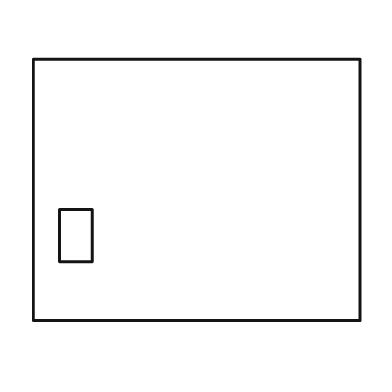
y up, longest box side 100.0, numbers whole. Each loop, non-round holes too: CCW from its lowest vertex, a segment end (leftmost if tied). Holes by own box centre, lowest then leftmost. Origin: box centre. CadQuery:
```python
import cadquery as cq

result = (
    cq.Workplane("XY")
    .moveTo(-50.0, -40.0)
    .lineTo(50.0, -40.0)
    .lineTo(50.0, 40.0)
    .lineTo(-50.0, 40.0)
    .close()
    .moveTo(-42.0, -22.0)
    .lineTo(-32.0, -22.0)
    .lineTo(-32.0, -6.0)
    .lineTo(-42.0, -6.0)
    .close()
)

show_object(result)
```